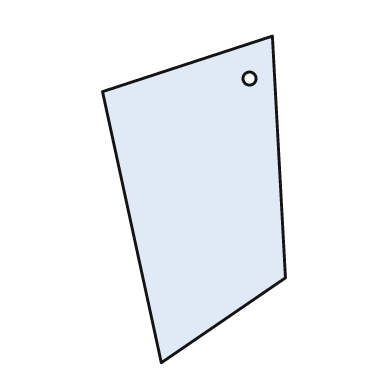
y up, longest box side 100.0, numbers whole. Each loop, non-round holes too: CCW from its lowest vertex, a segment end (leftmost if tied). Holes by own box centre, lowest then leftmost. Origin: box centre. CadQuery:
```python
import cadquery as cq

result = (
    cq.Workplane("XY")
    .moveTo(-10.0, -50.0)
    .lineTo(28.0, -24.0)
    .lineTo(24.0, 50.0)
    .lineTo(-28.0, 33.0)
    .close()
    .moveTo(17.0, 37.0)
    .circle(2.0)
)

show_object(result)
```